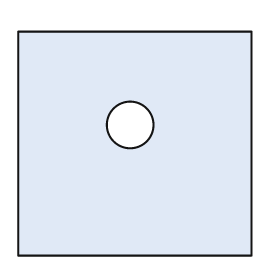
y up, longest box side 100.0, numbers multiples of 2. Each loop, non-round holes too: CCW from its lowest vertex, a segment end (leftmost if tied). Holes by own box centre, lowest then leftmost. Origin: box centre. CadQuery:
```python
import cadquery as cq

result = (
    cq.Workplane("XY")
    .moveTo(-50.0, -48.0)
    .lineTo(50.0, -48.0)
    .lineTo(50.0, 48.0)
    .lineTo(-50.0, 48.0)
    .close()
    .moveTo(-2.0, 8.0)
    .circle(10.0)
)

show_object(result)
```